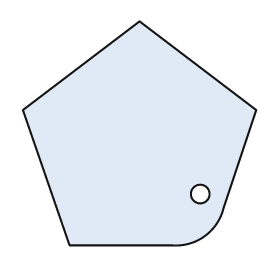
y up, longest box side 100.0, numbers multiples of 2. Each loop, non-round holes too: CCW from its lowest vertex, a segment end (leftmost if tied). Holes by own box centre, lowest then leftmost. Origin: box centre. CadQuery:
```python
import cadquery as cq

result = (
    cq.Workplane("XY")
    .moveTo(-30.0, -48.0)
    .lineTo(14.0, -48.0)
    .threePointArc((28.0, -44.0), (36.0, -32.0))
    .lineTo(50.0, 10.0)
    .lineTo(0.0, 48.0)
    .lineTo(-50.0, 10.0)
    .close()
    .moveTo(26.0, -26.0)
    .circle(4.0)
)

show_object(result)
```